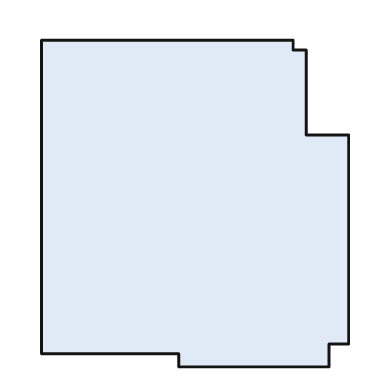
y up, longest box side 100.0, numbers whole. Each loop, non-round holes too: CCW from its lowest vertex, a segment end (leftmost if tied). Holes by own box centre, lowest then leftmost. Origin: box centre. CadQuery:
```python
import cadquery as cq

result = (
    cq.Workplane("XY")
    .moveTo(-5.0, -50.0)
    .lineTo(41.0, -50.0)
    .lineTo(41.0, -43.0)
    .lineTo(47.0, -43.0)
    .lineTo(47.0, 21.0)
    .lineTo(34.0, 21.0)
    .lineTo(34.0, 47.0)
    .lineTo(30.0, 47.0)
    .lineTo(30.0, 50.0)
    .lineTo(-47.0, 50.0)
    .lineTo(-47.0, -46.0)
    .lineTo(-5.0, -46.0)
    .close()
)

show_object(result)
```